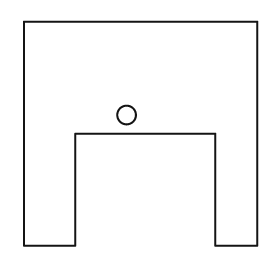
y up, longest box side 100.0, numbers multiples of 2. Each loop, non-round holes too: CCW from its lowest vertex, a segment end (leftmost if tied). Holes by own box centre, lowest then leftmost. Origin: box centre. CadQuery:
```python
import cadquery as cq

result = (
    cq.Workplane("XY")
    .moveTo(-50.0, -48.0)
    .lineTo(-28.0, -48.0)
    .lineTo(-28.0, 0.0)
    .lineTo(32.0, 0.0)
    .lineTo(32.0, -48.0)
    .lineTo(50.0, -48.0)
    .lineTo(50.0, 48.0)
    .lineTo(-50.0, 48.0)
    .close()
    .moveTo(-6.0, 8.0)
    .circle(4.0)
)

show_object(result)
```